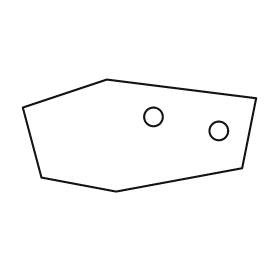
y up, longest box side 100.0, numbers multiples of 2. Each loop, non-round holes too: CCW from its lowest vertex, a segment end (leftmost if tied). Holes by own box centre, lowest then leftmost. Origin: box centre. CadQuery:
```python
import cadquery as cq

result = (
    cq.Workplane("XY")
    .moveTo(-10.0, -24.0)
    .lineTo(44.0, -14.0)
    .lineTo(50.0, 16.0)
    .lineTo(-14.0, 24.0)
    .lineTo(-50.0, 12.0)
    .lineTo(-42.0, -18.0)
    .close()
    .moveTo(34.0, 2.0)
    .circle(4.0)
    .moveTo(6.0, 8.0)
    .circle(4.0)
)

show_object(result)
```